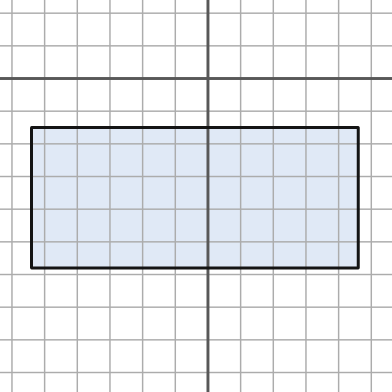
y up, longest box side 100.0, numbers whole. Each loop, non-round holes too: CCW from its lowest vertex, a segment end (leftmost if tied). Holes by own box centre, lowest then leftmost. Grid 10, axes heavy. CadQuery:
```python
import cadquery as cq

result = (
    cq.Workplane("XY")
    .moveTo(-54.0, -58.0)
    .lineTo(46.0, -58.0)
    .lineTo(46.0, -15.0)
    .lineTo(-54.0, -15.0)
    .close()
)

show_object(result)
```